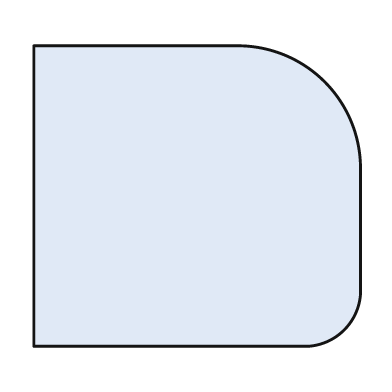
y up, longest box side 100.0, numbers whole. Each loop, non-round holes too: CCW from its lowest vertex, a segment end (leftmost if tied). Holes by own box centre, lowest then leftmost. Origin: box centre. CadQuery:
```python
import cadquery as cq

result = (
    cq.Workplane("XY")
    .moveTo(-50.0, -46.0)
    .lineTo(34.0, -46.0)
    .threePointArc((45.0, -41.0), (50.0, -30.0))
    .lineTo(50.0, 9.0)
    .threePointArc((39.0, 35.0), (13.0, 46.0))
    .lineTo(-50.0, 46.0)
    .close()
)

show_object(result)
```